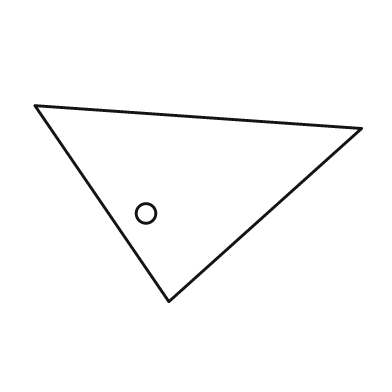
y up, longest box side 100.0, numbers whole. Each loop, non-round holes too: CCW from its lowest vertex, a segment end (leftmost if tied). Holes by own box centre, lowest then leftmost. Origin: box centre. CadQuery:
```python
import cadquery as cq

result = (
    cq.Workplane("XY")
    .moveTo(-9.0, -30.0)
    .lineTo(50.0, 23.0)
    .lineTo(-50.0, 30.0)
    .close()
    .moveTo(-16.0, -3.0)
    .circle(3.0)
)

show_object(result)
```